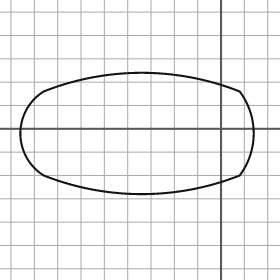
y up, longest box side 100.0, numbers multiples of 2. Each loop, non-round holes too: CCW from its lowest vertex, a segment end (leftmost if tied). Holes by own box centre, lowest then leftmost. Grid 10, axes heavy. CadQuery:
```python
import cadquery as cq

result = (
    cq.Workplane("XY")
    .moveTo(-76.0, -20.0)
    .threePointArc((-34.0, -28.0), (8.0, -20.0))
    .threePointArc((14.0, -2.0), (8.0, 16.0))
    .threePointArc((-34.0, 24.0), (-76.0, 16.0))
    .threePointArc((-86.0, -2.0), (-76.0, -20.0))
    .close()
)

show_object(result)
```